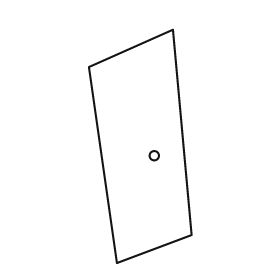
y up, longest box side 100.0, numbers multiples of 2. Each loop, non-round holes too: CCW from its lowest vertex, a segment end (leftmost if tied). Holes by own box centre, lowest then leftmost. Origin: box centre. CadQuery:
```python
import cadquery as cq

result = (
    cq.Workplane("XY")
    .moveTo(-10.0, -50.0)
    .lineTo(22.0, -38.0)
    .lineTo(14.0, 50.0)
    .lineTo(-22.0, 34.0)
    .close()
    .moveTo(6.0, -4.0)
    .circle(2.0)
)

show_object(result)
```